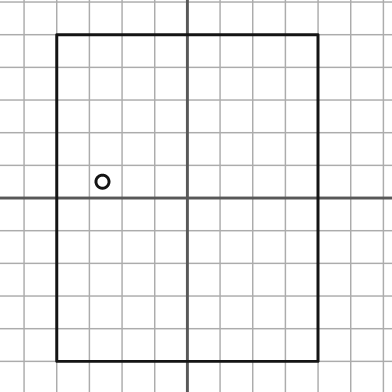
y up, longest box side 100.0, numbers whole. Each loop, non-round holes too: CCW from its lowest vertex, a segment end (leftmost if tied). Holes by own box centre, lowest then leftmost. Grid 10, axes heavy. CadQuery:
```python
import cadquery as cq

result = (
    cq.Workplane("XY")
    .moveTo(-40.0, -50.0)
    .lineTo(40.0, -50.0)
    .lineTo(40.0, 50.0)
    .lineTo(-40.0, 50.0)
    .close()
    .moveTo(-26.0, 5.0)
    .circle(2.0)
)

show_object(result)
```